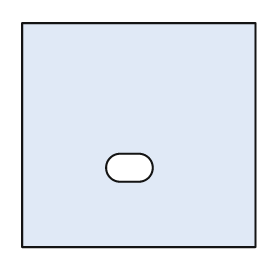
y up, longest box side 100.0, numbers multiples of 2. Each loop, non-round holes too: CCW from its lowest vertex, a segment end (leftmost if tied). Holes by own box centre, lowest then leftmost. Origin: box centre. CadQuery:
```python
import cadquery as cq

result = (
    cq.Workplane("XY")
    .moveTo(-50.0, -48.0)
    .lineTo(50.0, -48.0)
    .lineTo(50.0, 48.0)
    .lineTo(-50.0, 48.0)
    .close()
    .moveTo(-8.0, -20.0)
    .lineTo(0.0, -20.0)
    .threePointArc((6.0, -14.0), (0.0, -8.0))
    .lineTo(-8.0, -8.0)
    .threePointArc((-14.0, -14.0), (-8.0, -20.0))
    .close()
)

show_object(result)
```